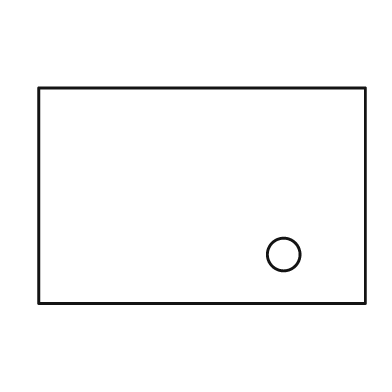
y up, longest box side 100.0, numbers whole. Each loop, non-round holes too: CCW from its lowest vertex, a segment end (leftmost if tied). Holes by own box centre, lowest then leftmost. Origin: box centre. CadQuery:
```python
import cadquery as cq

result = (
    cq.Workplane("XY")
    .moveTo(-50.0, -33.0)
    .lineTo(50.0, -33.0)
    .lineTo(50.0, 33.0)
    .lineTo(-50.0, 33.0)
    .close()
    .moveTo(25.0, -18.0)
    .circle(5.0)
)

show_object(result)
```